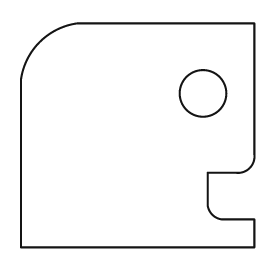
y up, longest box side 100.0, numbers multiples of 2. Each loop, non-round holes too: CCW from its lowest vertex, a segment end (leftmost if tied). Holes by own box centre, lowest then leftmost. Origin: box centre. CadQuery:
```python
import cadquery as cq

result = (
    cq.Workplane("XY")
    .moveTo(-50.0, -48.0)
    .lineTo(50.0, -48.0)
    .lineTo(50.0, -36.0)
    .lineTo(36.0, -36.0)
    .threePointArc((32.0, -34.0), (30.0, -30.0))
    .lineTo(30.0, -16.0)
    .lineTo(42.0, -16.0)
    .threePointArc((48.0, -14.0), (50.0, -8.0))
    .lineTo(50.0, 48.0)
    .lineTo(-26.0, 48.0)
    .threePointArc((-42.0, 40.0), (-50.0, 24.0))
    .close()
    .moveTo(28.0, 18.0)
    .circle(10.0)
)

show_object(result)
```